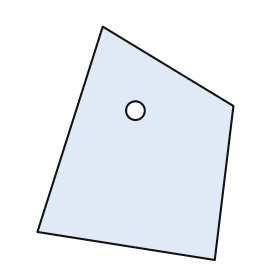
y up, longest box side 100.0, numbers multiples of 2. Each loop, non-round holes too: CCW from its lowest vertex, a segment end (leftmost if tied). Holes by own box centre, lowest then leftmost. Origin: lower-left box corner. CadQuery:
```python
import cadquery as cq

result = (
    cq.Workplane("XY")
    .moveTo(76.0, 0.0)
    .lineTo(84.0, 66.0)
    .lineTo(28.0, 100.0)
    .lineTo(0.0, 12.0)
    .close()
    .moveTo(42.0, 64.0)
    .circle(4.0)
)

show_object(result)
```